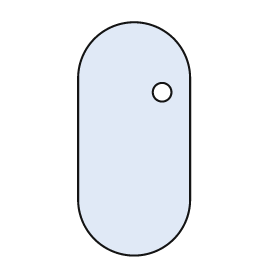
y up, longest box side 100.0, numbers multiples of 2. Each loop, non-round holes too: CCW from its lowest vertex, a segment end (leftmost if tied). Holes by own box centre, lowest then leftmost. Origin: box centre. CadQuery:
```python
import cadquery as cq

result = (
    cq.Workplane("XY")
    .moveTo(-24.0, -26.0)
    .threePointArc((0.0, -50.0), (24.0, -26.0))
    .lineTo(24.0, 26.0)
    .threePointArc((0.0, 50.0), (-24.0, 26.0))
    .close()
    .moveTo(12.0, 20.0)
    .circle(4.0)
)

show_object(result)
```